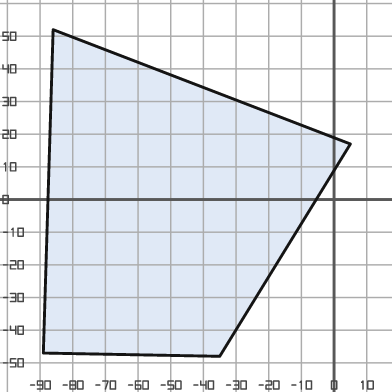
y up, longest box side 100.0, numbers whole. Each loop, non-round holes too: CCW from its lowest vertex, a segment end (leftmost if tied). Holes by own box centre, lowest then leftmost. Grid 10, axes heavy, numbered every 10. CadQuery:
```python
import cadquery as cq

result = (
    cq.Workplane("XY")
    .moveTo(-35.0, -48.0)
    .lineTo(5.0, 17.0)
    .lineTo(-86.0, 52.0)
    .lineTo(-89.0, -47.0)
    .close()
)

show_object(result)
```